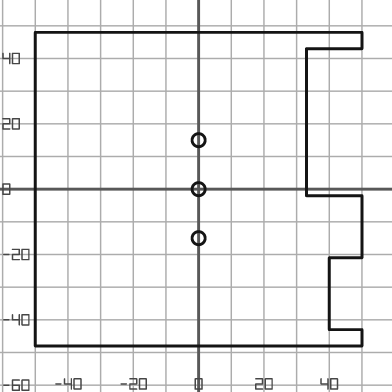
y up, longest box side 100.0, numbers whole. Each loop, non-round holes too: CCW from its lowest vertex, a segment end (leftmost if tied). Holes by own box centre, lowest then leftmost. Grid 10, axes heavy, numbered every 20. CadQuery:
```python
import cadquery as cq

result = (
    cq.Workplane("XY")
    .moveTo(-50.0, -48.0)
    .lineTo(50.0, -48.0)
    .lineTo(50.0, -43.0)
    .lineTo(40.0, -43.0)
    .lineTo(40.0, -21.0)
    .lineTo(50.0, -21.0)
    .lineTo(50.0, -2.0)
    .lineTo(33.0, -2.0)
    .lineTo(33.0, 43.0)
    .lineTo(50.0, 43.0)
    .lineTo(50.0, 48.0)
    .lineTo(-50.0, 48.0)
    .close()
    .moveTo(0.0, -15.0)
    .circle(2.0)
    .moveTo(0.0, 0.0)
    .circle(2.0)
    .moveTo(0.0, 15.0)
    .circle(2.0)
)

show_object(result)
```